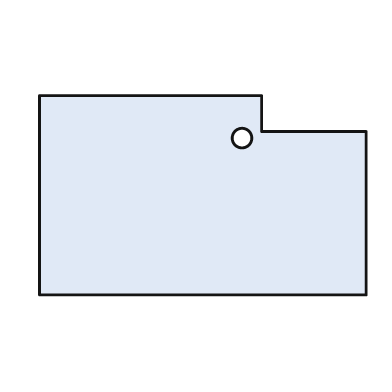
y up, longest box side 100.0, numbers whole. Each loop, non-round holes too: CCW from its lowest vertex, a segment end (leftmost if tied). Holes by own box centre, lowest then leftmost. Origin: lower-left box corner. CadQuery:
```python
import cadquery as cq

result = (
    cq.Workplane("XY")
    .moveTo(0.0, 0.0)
    .lineTo(100.0, 0.0)
    .lineTo(100.0, 50.0)
    .lineTo(68.0, 50.0)
    .lineTo(68.0, 61.0)
    .lineTo(0.0, 61.0)
    .close()
    .moveTo(62.0, 48.0)
    .circle(3.0)
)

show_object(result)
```